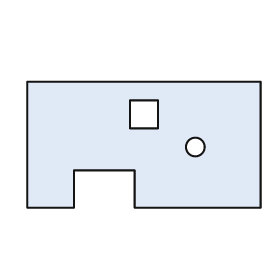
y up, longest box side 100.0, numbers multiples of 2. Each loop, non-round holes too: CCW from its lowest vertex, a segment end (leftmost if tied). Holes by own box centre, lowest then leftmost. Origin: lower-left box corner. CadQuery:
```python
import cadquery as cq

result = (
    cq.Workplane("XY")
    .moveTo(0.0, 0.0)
    .lineTo(20.0, 0.0)
    .lineTo(20.0, 16.0)
    .lineTo(46.0, 16.0)
    .lineTo(46.0, 0.0)
    .lineTo(100.0, 0.0)
    .lineTo(100.0, 54.0)
    .lineTo(0.0, 54.0)
    .close()
    .moveTo(72.0, 26.0)
    .circle(4.0)
    .moveTo(44.0, 34.0)
    .lineTo(56.0, 34.0)
    .lineTo(56.0, 46.0)
    .lineTo(44.0, 46.0)
    .close()
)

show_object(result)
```